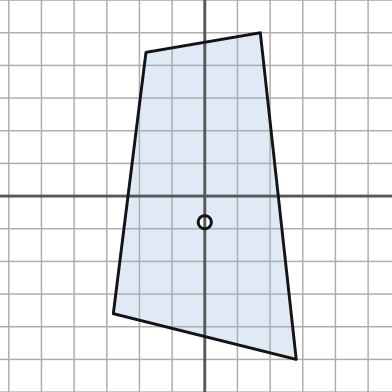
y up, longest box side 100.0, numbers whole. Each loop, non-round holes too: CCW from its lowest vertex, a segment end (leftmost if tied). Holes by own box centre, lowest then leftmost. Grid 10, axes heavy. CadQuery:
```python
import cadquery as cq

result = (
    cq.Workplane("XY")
    .moveTo(28.0, -50.0)
    .lineTo(17.0, 50.0)
    .lineTo(-18.0, 44.0)
    .lineTo(-28.0, -36.0)
    .close()
    .moveTo(0.0, -8.0)
    .circle(2.0)
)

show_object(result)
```